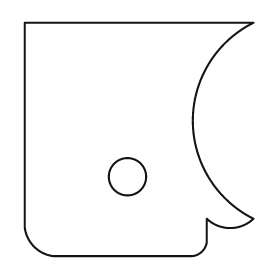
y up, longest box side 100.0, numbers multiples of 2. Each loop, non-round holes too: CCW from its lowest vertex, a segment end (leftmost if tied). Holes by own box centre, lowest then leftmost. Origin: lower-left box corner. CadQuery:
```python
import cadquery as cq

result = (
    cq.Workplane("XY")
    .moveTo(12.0, 0.0)
    .lineTo(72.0, 0.0)
    .threePointArc((76.0, 2.0), (78.0, 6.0))
    .lineTo(78.0, 16.0)
    .threePointArc((88.0, 12.0), (98.0, 16.0))
    .threePointArc((72.0, 58.0), (98.0, 100.0))
    .lineTo(0.0, 100.0)
    .lineTo(0.0, 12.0)
    .threePointArc((4.0, 4.0), (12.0, 0.0))
    .close()
    .moveTo(44.0, 34.0)
    .circle(8.0)
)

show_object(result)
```